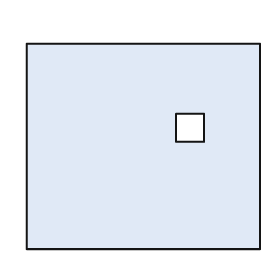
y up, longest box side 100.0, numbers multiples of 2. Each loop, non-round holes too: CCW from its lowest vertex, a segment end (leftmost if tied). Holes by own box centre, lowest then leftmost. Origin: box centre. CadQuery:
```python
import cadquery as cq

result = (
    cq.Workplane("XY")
    .moveTo(-50.0, -44.0)
    .lineTo(50.0, -44.0)
    .lineTo(50.0, 44.0)
    .lineTo(-50.0, 44.0)
    .close()
    .moveTo(14.0, 2.0)
    .lineTo(26.0, 2.0)
    .lineTo(26.0, 14.0)
    .lineTo(14.0, 14.0)
    .close()
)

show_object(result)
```